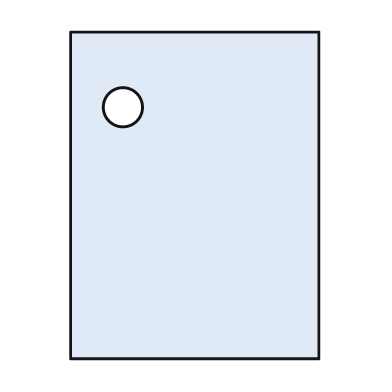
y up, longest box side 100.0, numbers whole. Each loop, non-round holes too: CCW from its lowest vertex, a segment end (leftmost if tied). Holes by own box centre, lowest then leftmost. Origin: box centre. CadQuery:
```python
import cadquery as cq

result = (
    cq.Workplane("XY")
    .moveTo(-38.0, -50.0)
    .lineTo(38.0, -50.0)
    .lineTo(38.0, 50.0)
    .lineTo(-38.0, 50.0)
    .close()
    .moveTo(-22.0, 27.0)
    .circle(6.0)
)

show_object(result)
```